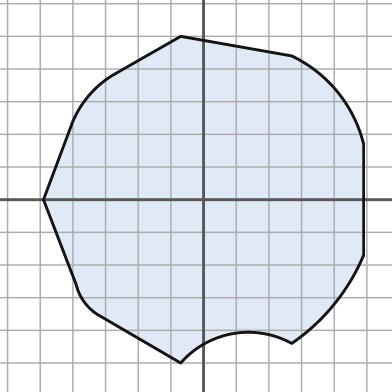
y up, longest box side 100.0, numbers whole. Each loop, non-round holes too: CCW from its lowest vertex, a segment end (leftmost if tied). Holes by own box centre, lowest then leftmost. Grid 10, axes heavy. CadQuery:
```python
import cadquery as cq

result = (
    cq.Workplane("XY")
    .moveTo(-7.0, -50.0)
    .threePointArc((9.0, -41.0), (27.0, -44.0))
    .threePointArc((40.0, -32.0), (49.0, -17.0))
    .lineTo(49.0, 17.0)
    .threePointArc((41.0, 33.0), (27.0, 44.0))
    .lineTo(-7.0, 50.0)
    .lineTo(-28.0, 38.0)
    .threePointArc((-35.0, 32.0), (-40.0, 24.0))
    .lineTo(-49.0, 0.0)
    .lineTo(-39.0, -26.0)
    .threePointArc((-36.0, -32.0), (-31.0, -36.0))
    .close()
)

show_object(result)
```